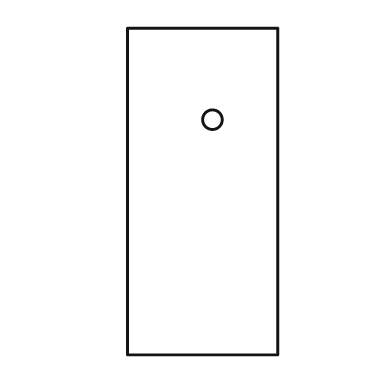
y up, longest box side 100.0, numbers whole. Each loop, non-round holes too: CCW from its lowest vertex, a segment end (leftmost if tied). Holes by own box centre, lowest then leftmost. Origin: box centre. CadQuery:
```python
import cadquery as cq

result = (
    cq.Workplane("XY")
    .moveTo(-23.0, -50.0)
    .lineTo(23.0, -50.0)
    .lineTo(23.0, 50.0)
    .lineTo(-23.0, 50.0)
    .close()
    .moveTo(3.0, 22.0)
    .circle(3.0)
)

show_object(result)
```